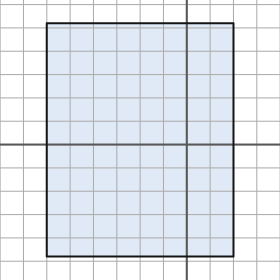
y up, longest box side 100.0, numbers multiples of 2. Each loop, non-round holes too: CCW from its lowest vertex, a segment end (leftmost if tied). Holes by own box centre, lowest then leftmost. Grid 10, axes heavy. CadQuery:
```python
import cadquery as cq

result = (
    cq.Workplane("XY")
    .moveTo(-60.0, -48.0)
    .lineTo(20.0, -48.0)
    .lineTo(20.0, 52.0)
    .lineTo(-60.0, 52.0)
    .close()
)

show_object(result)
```